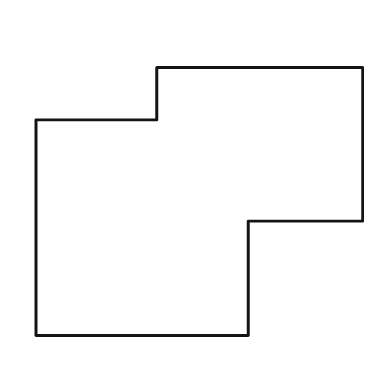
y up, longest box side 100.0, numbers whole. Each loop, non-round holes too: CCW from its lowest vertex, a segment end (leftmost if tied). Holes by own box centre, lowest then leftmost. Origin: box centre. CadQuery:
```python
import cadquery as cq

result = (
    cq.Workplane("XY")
    .moveTo(-50.0, -41.0)
    .lineTo(15.0, -41.0)
    .lineTo(15.0, -6.0)
    .lineTo(50.0, -6.0)
    .lineTo(50.0, 41.0)
    .lineTo(-13.0, 41.0)
    .lineTo(-13.0, 25.0)
    .lineTo(-50.0, 25.0)
    .close()
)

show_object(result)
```